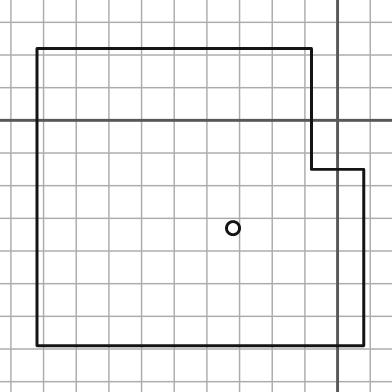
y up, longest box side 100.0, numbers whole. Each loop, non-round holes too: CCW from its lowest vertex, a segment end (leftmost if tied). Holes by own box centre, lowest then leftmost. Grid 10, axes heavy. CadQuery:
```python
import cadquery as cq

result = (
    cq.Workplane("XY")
    .moveTo(-92.0, -69.0)
    .lineTo(8.0, -69.0)
    .lineTo(8.0, -15.0)
    .lineTo(-8.0, -15.0)
    .lineTo(-8.0, 22.0)
    .lineTo(-92.0, 22.0)
    .close()
    .moveTo(-32.0, -33.0)
    .circle(2.0)
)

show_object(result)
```